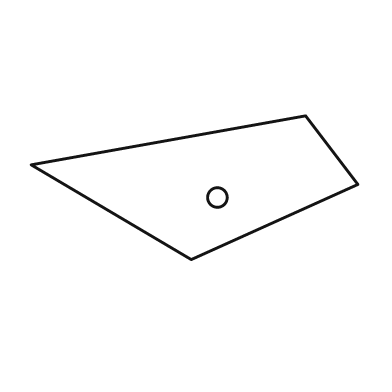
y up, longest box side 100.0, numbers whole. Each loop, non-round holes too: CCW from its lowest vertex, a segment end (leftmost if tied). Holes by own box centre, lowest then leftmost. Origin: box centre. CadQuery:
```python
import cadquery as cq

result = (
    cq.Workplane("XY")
    .moveTo(-1.0, -22.0)
    .lineTo(50.0, 1.0)
    .lineTo(34.0, 22.0)
    .lineTo(-50.0, 7.0)
    .close()
    .moveTo(7.0, -3.0)
    .circle(3.0)
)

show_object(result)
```